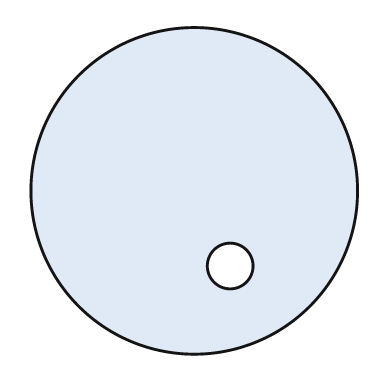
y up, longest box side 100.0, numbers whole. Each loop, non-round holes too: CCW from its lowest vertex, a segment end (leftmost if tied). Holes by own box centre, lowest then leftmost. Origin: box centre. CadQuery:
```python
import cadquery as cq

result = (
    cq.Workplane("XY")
    .moveTo(0.0, 0.0)
    .circle(50.0)
    .moveTo(11.0, -23.0)
    .circle(7.0)
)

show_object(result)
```